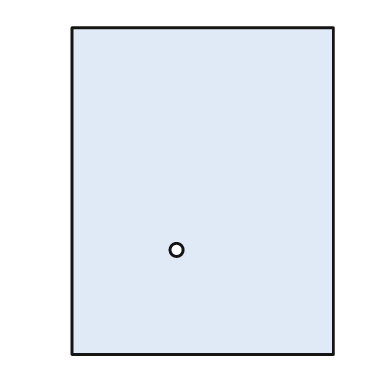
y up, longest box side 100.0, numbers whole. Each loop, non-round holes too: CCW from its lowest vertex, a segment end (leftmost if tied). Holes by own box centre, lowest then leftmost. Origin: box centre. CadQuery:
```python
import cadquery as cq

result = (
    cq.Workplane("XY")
    .moveTo(-40.0, -50.0)
    .lineTo(40.0, -50.0)
    .lineTo(40.0, 50.0)
    .lineTo(-40.0, 50.0)
    .close()
    .moveTo(-8.0, -18.0)
    .circle(2.0)
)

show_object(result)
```